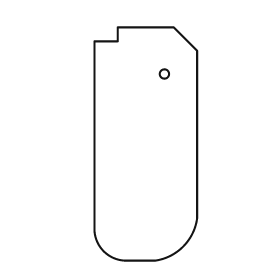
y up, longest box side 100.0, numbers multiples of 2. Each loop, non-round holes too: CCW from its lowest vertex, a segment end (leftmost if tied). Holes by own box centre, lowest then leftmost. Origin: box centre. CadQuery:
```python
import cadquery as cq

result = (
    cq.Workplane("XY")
    .moveTo(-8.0, -50.0)
    .lineTo(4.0, -50.0)
    .threePointArc((16.0, -44.0), (22.0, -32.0))
    .lineTo(22.0, 40.0)
    .lineTo(12.0, 50.0)
    .lineTo(-12.0, 50.0)
    .lineTo(-12.0, 44.0)
    .lineTo(-22.0, 44.0)
    .lineTo(-22.0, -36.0)
    .threePointArc((-18.0, -46.0), (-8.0, -50.0))
    .close()
    .moveTo(8.0, 30.0)
    .circle(2.0)
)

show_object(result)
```